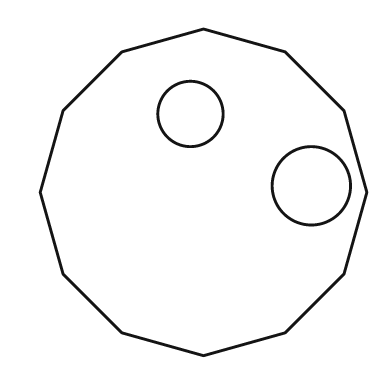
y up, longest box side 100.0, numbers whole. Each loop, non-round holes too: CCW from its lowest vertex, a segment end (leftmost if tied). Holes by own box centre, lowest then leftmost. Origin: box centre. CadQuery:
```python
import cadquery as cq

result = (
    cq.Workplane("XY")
    .moveTo(0.0, -50.0)
    .lineTo(25.0, -43.0)
    .lineTo(43.0, -25.0)
    .lineTo(50.0, 0.0)
    .lineTo(43.0, 25.0)
    .lineTo(25.0, 43.0)
    .lineTo(0.0, 50.0)
    .lineTo(-25.0, 43.0)
    .lineTo(-43.0, 25.0)
    .lineTo(-50.0, 0.0)
    .lineTo(-43.0, -25.0)
    .lineTo(-25.0, -43.0)
    .close()
    .moveTo(33.0, 2.0)
    .circle(12.0)
    .moveTo(-4.0, 24.0)
    .circle(10.0)
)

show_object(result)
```